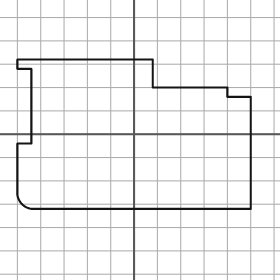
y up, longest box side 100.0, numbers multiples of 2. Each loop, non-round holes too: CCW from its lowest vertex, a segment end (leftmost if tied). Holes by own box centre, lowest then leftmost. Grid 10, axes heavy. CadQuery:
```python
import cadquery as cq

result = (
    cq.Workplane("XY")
    .moveTo(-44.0, -32.0)
    .lineTo(50.0, -32.0)
    .lineTo(50.0, 16.0)
    .lineTo(40.0, 16.0)
    .lineTo(40.0, 20.0)
    .lineTo(8.0, 20.0)
    .lineTo(8.0, 32.0)
    .lineTo(-50.0, 32.0)
    .lineTo(-50.0, 28.0)
    .lineTo(-44.0, 28.0)
    .lineTo(-44.0, -4.0)
    .lineTo(-50.0, -4.0)
    .lineTo(-50.0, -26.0)
    .threePointArc((-48.0, -30.0), (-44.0, -32.0))
    .close()
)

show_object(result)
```